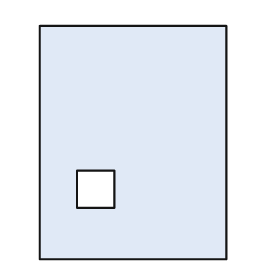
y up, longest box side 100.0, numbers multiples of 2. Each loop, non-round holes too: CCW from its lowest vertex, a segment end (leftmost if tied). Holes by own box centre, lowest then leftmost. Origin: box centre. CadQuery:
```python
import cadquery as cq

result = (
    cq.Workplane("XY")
    .moveTo(-40.0, -50.0)
    .lineTo(40.0, -50.0)
    .lineTo(40.0, 50.0)
    .lineTo(-40.0, 50.0)
    .close()
    .moveTo(-24.0, -28.0)
    .lineTo(-8.0, -28.0)
    .lineTo(-8.0, -12.0)
    .lineTo(-24.0, -12.0)
    .close()
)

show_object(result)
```